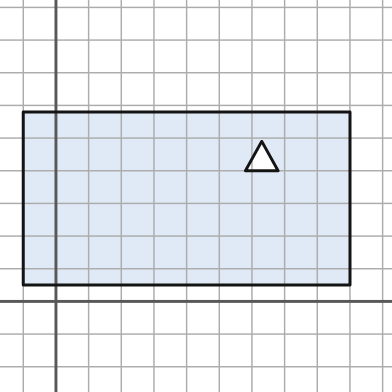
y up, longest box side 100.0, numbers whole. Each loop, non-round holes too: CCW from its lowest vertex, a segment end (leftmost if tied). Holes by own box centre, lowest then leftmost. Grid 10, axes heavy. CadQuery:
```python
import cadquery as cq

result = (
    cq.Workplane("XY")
    .moveTo(-10.0, 5.0)
    .lineTo(90.0, 5.0)
    .lineTo(90.0, 58.0)
    .lineTo(-10.0, 58.0)
    .close()
    .moveTo(58.0, 40.0)
    .lineTo(68.0, 40.0)
    .lineTo(63.0, 49.0)
    .close()
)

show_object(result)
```